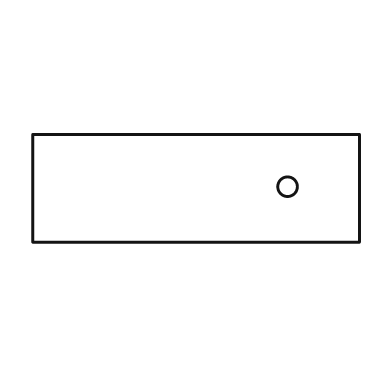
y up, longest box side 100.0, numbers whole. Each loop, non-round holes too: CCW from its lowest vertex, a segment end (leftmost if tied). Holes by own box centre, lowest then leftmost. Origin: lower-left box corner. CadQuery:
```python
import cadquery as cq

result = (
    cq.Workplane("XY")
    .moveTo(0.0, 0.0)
    .lineTo(100.0, 0.0)
    .lineTo(100.0, 33.0)
    .lineTo(0.0, 33.0)
    .close()
    .moveTo(78.0, 17.0)
    .circle(3.0)
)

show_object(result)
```